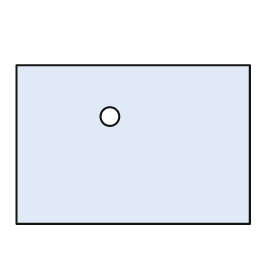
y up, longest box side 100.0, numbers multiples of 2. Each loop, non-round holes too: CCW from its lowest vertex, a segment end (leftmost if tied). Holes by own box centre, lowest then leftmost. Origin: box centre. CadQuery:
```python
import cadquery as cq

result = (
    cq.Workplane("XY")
    .moveTo(-50.0, -34.0)
    .lineTo(50.0, -34.0)
    .lineTo(50.0, 34.0)
    .lineTo(-50.0, 34.0)
    .close()
    .moveTo(-10.0, 12.0)
    .circle(4.0)
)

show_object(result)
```